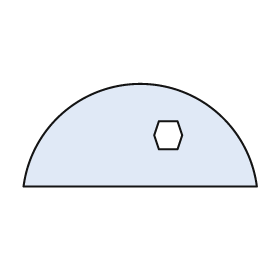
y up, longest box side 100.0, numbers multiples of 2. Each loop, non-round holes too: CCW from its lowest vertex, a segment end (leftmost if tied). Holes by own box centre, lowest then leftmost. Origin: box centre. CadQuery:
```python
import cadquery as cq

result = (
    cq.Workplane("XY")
    .moveTo(-50.0, -22.0)
    .lineTo(50.0, -22.0)
    .threePointArc((0.0, 22.0), (-50.0, -22.0))
    .close()
    .moveTo(8.0, -6.0)
    .lineTo(16.0, -6.0)
    .lineTo(18.0, 0.0)
    .lineTo(16.0, 6.0)
    .lineTo(8.0, 6.0)
    .lineTo(6.0, 0.0)
    .close()
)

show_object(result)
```